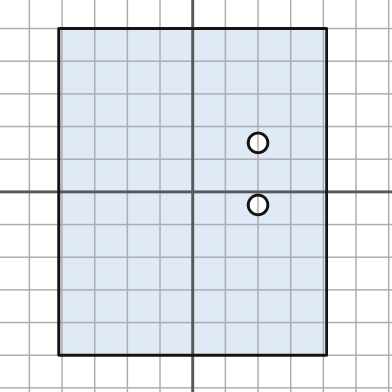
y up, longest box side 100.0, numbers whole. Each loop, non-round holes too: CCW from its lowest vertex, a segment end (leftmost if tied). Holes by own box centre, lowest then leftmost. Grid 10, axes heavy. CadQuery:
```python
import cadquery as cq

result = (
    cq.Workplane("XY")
    .moveTo(-41.0, -50.0)
    .lineTo(41.0, -50.0)
    .lineTo(41.0, 50.0)
    .lineTo(-41.0, 50.0)
    .close()
    .moveTo(20.0, -4.0)
    .circle(3.0)
    .moveTo(20.0, 15.0)
    .circle(3.0)
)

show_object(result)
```